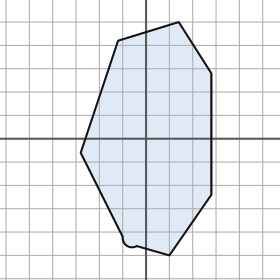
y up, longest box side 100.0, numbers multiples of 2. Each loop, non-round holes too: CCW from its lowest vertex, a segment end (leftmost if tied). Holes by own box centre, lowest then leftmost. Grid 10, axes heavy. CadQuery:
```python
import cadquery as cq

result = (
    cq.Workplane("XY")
    .moveTo(10.0, -50.0)
    .lineTo(28.0, -24.0)
    .lineTo(28.0, 28.0)
    .lineTo(14.0, 50.0)
    .lineTo(-12.0, 42.0)
    .lineTo(-28.0, -6.0)
    .lineTo(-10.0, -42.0)
    .threePointArc((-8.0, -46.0), (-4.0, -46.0))
    .close()
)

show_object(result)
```